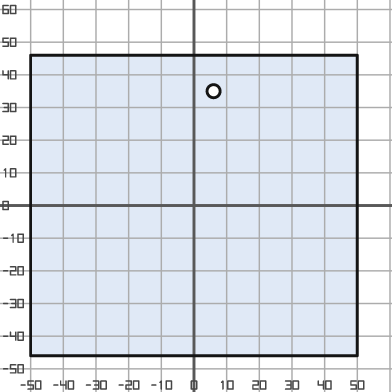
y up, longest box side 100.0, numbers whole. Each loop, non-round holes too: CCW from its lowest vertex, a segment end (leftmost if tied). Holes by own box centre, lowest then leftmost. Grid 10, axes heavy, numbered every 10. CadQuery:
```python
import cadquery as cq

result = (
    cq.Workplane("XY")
    .moveTo(-50.0, -46.0)
    .lineTo(50.0, -46.0)
    .lineTo(50.0, 46.0)
    .lineTo(-50.0, 46.0)
    .close()
    .moveTo(6.0, 35.0)
    .circle(2.0)
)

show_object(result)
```